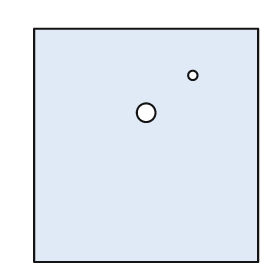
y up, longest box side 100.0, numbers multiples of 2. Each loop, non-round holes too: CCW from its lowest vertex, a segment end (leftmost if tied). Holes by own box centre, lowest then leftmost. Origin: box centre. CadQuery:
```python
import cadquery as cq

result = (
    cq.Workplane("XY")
    .moveTo(-48.0, -50.0)
    .lineTo(48.0, -50.0)
    .lineTo(48.0, 50.0)
    .lineTo(-48.0, 50.0)
    .close()
    .moveTo(0.0, 14.0)
    .circle(4.0)
    .moveTo(20.0, 30.0)
    .circle(2.0)
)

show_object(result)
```